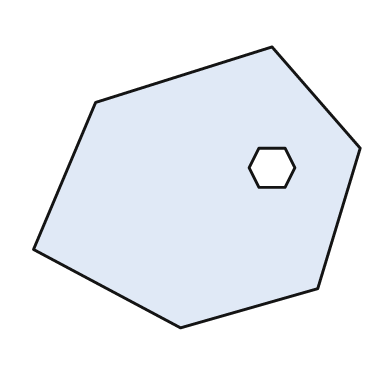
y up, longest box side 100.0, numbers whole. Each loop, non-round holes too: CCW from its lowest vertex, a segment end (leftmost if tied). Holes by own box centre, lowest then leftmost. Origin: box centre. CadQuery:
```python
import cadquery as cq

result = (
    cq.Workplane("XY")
    .moveTo(-5.0, -43.0)
    .lineTo(37.0, -31.0)
    .lineTo(50.0, 12.0)
    .lineTo(23.0, 43.0)
    .lineTo(-31.0, 26.0)
    .lineTo(-50.0, -19.0)
    .close()
    .moveTo(19.0, 0.0)
    .lineTo(27.0, 0.0)
    .lineTo(30.0, 6.0)
    .lineTo(27.0, 12.0)
    .lineTo(19.0, 12.0)
    .lineTo(16.0, 6.0)
    .close()
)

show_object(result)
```